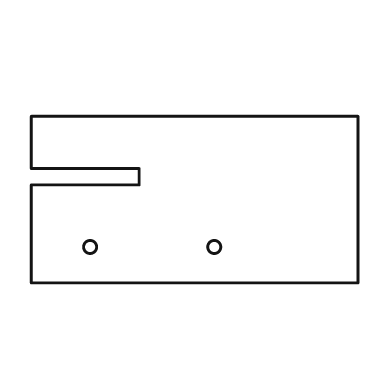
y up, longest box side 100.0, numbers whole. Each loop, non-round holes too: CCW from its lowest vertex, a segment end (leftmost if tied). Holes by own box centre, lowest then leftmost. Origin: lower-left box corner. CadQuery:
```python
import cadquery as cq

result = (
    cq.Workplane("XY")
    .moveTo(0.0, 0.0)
    .lineTo(100.0, 0.0)
    .lineTo(100.0, 51.0)
    .lineTo(0.0, 51.0)
    .lineTo(0.0, 35.0)
    .lineTo(33.0, 35.0)
    .lineTo(33.0, 30.0)
    .lineTo(0.0, 30.0)
    .close()
    .moveTo(18.0, 11.0)
    .circle(2.0)
    .moveTo(56.0, 11.0)
    .circle(2.0)
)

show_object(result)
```